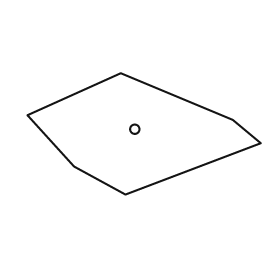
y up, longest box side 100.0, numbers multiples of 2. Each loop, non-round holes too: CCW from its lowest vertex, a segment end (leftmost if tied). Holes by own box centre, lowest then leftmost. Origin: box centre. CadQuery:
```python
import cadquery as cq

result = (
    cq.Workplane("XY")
    .moveTo(-8.0, -26.0)
    .lineTo(50.0, -4.0)
    .lineTo(38.0, 6.0)
    .lineTo(-10.0, 26.0)
    .lineTo(-50.0, 8.0)
    .lineTo(-30.0, -14.0)
    .close()
    .moveTo(-4.0, 2.0)
    .circle(2.0)
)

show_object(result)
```